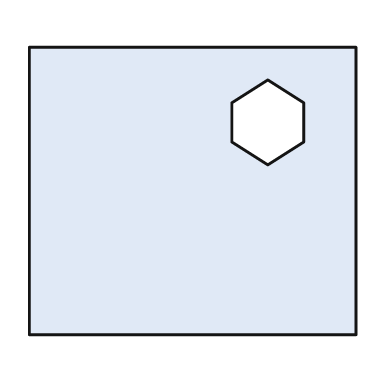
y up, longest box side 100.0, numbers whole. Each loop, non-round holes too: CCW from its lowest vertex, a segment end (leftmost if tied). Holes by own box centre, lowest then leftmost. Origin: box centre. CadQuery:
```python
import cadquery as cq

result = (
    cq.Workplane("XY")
    .moveTo(-50.0, -44.0)
    .lineTo(50.0, -44.0)
    .lineTo(50.0, 44.0)
    .lineTo(-50.0, 44.0)
    .close()
    .moveTo(23.0, 8.0)
    .lineTo(34.0, 15.0)
    .lineTo(34.0, 27.0)
    .lineTo(23.0, 34.0)
    .lineTo(12.0, 27.0)
    .lineTo(12.0, 15.0)
    .close()
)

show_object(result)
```